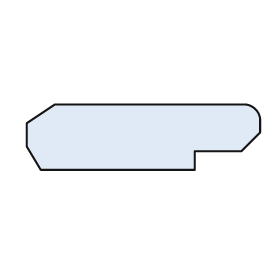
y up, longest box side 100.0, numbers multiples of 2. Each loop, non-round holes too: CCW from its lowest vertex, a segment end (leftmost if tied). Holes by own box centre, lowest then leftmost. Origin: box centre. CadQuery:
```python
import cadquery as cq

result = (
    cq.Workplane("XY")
    .moveTo(-44.0, -14.0)
    .lineTo(22.0, -14.0)
    .lineTo(22.0, -6.0)
    .lineTo(42.0, -6.0)
    .lineTo(50.0, 2.0)
    .lineTo(50.0, 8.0)
    .threePointArc((48.0, 12.0), (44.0, 14.0))
    .lineTo(-38.0, 14.0)
    .lineTo(-50.0, 6.0)
    .lineTo(-50.0, -4.0)
    .close()
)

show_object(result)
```